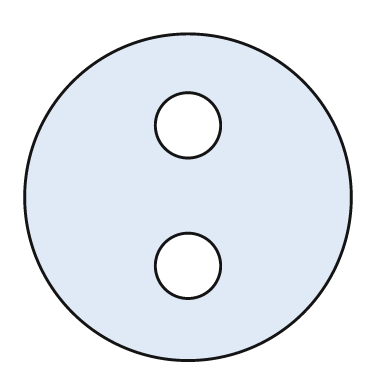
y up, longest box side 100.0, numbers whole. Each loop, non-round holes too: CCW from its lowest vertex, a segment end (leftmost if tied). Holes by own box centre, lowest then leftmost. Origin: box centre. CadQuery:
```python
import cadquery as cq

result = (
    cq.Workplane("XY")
    .moveTo(0.0, 0.0)
    .circle(50.0)
    .moveTo(0.0, -21.0)
    .circle(10.0)
    .moveTo(0.0, 22.0)
    .circle(10.0)
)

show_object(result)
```